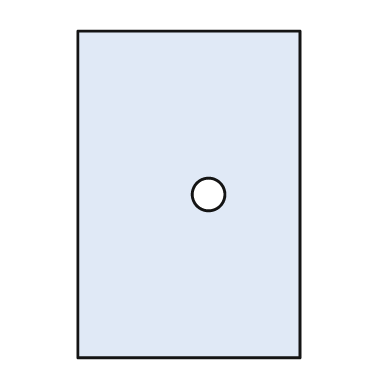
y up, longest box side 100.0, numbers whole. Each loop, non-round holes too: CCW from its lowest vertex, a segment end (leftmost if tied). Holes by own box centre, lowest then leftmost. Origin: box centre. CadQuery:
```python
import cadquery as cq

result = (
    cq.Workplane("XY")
    .moveTo(-34.0, -50.0)
    .lineTo(34.0, -50.0)
    .lineTo(34.0, 50.0)
    .lineTo(-34.0, 50.0)
    .close()
    .moveTo(6.0, 0.0)
    .circle(5.0)
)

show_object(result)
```